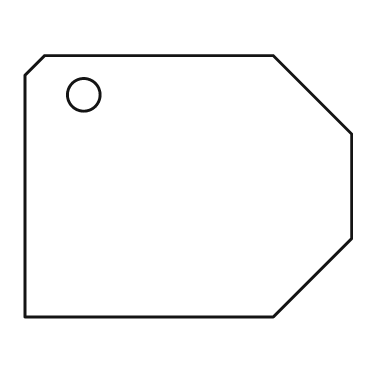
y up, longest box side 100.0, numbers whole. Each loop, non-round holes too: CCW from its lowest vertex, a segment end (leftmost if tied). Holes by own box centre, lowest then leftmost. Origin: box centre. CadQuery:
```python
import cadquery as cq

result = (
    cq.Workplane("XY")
    .moveTo(-50.0, -40.0)
    .lineTo(26.0, -40.0)
    .lineTo(50.0, -16.0)
    .lineTo(50.0, 16.0)
    .lineTo(26.0, 40.0)
    .lineTo(-44.0, 40.0)
    .lineTo(-50.0, 34.0)
    .close()
    .moveTo(-32.0, 28.0)
    .circle(5.0)
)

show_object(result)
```